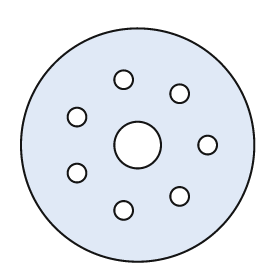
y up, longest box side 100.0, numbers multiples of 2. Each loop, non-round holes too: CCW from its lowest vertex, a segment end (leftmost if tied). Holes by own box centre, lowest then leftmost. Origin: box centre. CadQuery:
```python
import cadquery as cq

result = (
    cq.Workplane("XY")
    .moveTo(0.0, 0.0)
    .circle(50.0)
    .moveTo(-6.0, -28.0)
    .circle(4.0)
    .moveTo(18.0, -22.0)
    .circle(4.0)
    .moveTo(-26.0, -12.0)
    .circle(4.0)
    .moveTo(0.0, 0.0)
    .circle(10.0)
    .moveTo(30.0, 0.0)
    .circle(4.0)
    .moveTo(-26.0, 12.0)
    .circle(4.0)
    .moveTo(18.0, 22.0)
    .circle(4.0)
    .moveTo(-6.0, 28.0)
    .circle(4.0)
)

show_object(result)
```